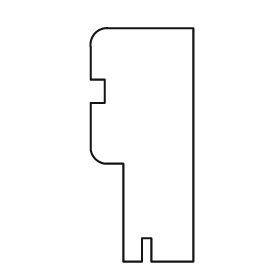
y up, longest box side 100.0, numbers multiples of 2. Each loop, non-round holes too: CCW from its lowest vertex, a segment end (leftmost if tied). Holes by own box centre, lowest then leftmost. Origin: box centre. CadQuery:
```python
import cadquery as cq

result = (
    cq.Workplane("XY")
    .moveTo(-8.0, -50.0)
    .lineTo(0.0, -50.0)
    .lineTo(0.0, -40.0)
    .lineTo(4.0, -40.0)
    .lineTo(4.0, -50.0)
    .lineTo(22.0, -50.0)
    .lineTo(22.0, 50.0)
    .lineTo(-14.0, 50.0)
    .threePointArc((-20.0, 48.0), (-22.0, 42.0))
    .lineTo(-22.0, 28.0)
    .lineTo(-16.0, 28.0)
    .lineTo(-16.0, 18.0)
    .lineTo(-22.0, 18.0)
    .lineTo(-22.0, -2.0)
    .threePointArc((-20.0, -6.0), (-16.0, -8.0))
    .lineTo(-8.0, -8.0)
    .close()
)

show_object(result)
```